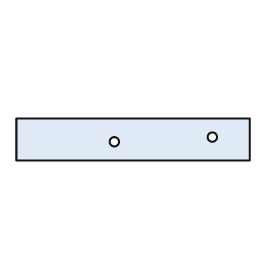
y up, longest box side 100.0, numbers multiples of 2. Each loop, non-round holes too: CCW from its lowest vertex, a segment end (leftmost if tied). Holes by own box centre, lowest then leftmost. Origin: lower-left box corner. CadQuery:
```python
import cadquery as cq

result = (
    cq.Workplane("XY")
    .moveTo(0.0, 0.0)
    .lineTo(100.0, 0.0)
    .lineTo(100.0, 18.0)
    .lineTo(0.0, 18.0)
    .close()
    .moveTo(42.0, 8.0)
    .circle(2.0)
    .moveTo(84.0, 10.0)
    .circle(2.0)
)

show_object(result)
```